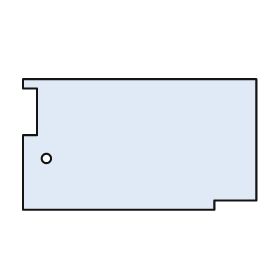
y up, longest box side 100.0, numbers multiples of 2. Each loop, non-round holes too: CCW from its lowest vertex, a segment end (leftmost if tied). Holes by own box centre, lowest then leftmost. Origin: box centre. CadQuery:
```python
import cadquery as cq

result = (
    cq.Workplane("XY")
    .moveTo(-50.0, -28.0)
    .lineTo(32.0, -28.0)
    .lineTo(32.0, -24.0)
    .lineTo(50.0, -24.0)
    .lineTo(50.0, 28.0)
    .lineTo(-50.0, 28.0)
    .lineTo(-50.0, 24.0)
    .lineTo(-44.0, 24.0)
    .lineTo(-44.0, 4.0)
    .lineTo(-50.0, 4.0)
    .close()
    .moveTo(-40.0, -6.0)
    .circle(2.0)
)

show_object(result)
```